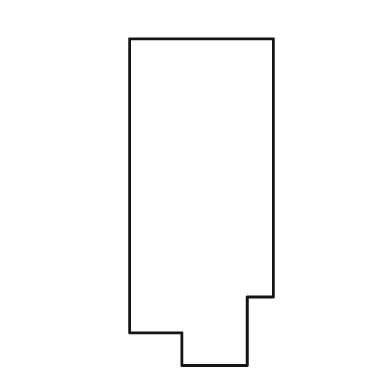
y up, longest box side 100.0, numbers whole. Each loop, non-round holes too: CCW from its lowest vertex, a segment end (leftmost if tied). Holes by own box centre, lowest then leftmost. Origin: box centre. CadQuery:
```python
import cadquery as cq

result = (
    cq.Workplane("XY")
    .moveTo(-6.0, -50.0)
    .lineTo(14.0, -50.0)
    .lineTo(14.0, -29.0)
    .lineTo(22.0, -29.0)
    .lineTo(22.0, 50.0)
    .lineTo(-22.0, 50.0)
    .lineTo(-22.0, -40.0)
    .lineTo(-6.0, -40.0)
    .close()
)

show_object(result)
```